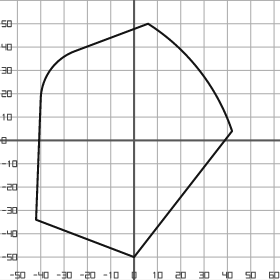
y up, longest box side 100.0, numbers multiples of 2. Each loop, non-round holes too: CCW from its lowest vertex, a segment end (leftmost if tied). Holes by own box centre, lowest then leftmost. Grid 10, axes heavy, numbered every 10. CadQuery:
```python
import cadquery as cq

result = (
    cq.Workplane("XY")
    .moveTo(0.0, -50.0)
    .lineTo(42.0, 4.0)
    .threePointArc((28.0, 30.0), (6.0, 50.0))
    .lineTo(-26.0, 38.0)
    .threePointArc((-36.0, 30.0), (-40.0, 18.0))
    .lineTo(-42.0, -34.0)
    .close()
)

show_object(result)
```